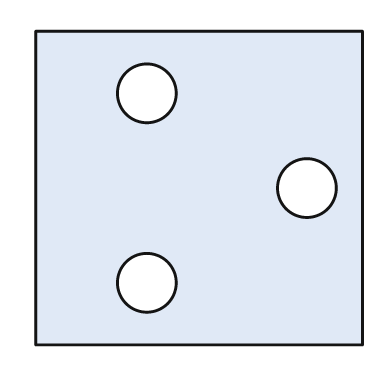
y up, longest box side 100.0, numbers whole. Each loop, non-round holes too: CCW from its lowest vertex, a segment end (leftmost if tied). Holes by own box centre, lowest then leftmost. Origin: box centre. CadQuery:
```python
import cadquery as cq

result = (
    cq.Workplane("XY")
    .moveTo(-50.0, -48.0)
    .lineTo(50.0, -48.0)
    .lineTo(50.0, 48.0)
    .lineTo(-50.0, 48.0)
    .close()
    .moveTo(-16.0, -29.0)
    .circle(9.0)
    .moveTo(33.0, 0.0)
    .circle(9.0)
    .moveTo(-16.0, 29.0)
    .circle(9.0)
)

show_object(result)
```